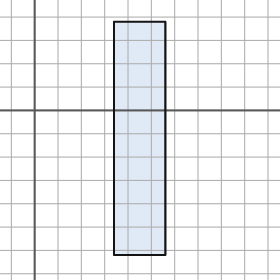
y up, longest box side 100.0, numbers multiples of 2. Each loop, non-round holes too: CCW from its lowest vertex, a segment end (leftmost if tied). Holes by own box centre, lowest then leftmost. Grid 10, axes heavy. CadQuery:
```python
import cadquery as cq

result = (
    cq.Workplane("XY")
    .moveTo(34.0, -62.0)
    .lineTo(56.0, -62.0)
    .lineTo(56.0, 38.0)
    .lineTo(34.0, 38.0)
    .close()
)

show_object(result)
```